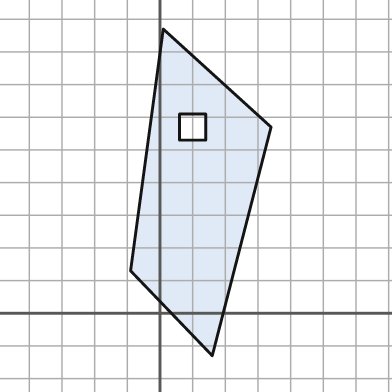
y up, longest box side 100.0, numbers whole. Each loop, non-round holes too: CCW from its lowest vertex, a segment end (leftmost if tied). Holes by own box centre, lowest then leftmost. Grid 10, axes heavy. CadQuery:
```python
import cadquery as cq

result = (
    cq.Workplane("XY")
    .moveTo(16.0, -13.0)
    .lineTo(34.0, 57.0)
    .lineTo(1.0, 87.0)
    .lineTo(-9.0, 13.0)
    .close()
    .moveTo(6.0, 53.0)
    .lineTo(14.0, 53.0)
    .lineTo(14.0, 61.0)
    .lineTo(6.0, 61.0)
    .close()
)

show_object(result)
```